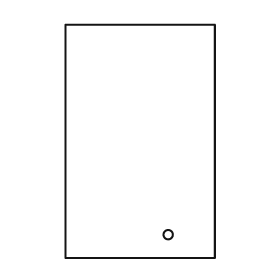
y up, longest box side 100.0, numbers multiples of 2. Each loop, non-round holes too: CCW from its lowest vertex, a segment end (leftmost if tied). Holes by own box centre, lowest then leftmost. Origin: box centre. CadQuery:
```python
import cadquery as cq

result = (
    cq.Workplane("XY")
    .moveTo(-32.0, -50.0)
    .lineTo(32.0, -50.0)
    .lineTo(32.0, 50.0)
    .lineTo(-32.0, 50.0)
    .close()
    .moveTo(12.0, -40.0)
    .circle(2.0)
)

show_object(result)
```